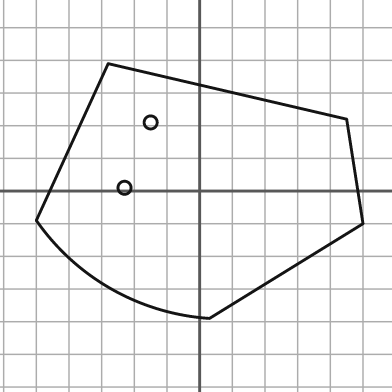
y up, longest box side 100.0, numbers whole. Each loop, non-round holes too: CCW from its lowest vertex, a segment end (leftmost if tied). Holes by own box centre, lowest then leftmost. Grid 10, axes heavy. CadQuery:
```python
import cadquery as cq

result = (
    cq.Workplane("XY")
    .moveTo(3.0, -39.0)
    .lineTo(50.0, -10.0)
    .lineTo(45.0, 22.0)
    .lineTo(-28.0, 39.0)
    .lineTo(-50.0, -9.0)
    .threePointArc((-27.0, -30.0), (3.0, -39.0))
    .close()
    .moveTo(-23.0, 1.0)
    .circle(2.0)
    .moveTo(-15.0, 21.0)
    .circle(2.0)
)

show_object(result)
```